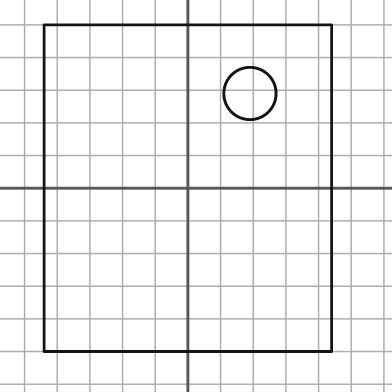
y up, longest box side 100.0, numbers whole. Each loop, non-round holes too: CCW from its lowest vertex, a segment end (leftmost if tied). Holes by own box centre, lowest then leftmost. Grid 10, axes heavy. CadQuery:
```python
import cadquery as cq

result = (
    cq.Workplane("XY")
    .moveTo(-44.0, -50.0)
    .lineTo(44.0, -50.0)
    .lineTo(44.0, 50.0)
    .lineTo(-44.0, 50.0)
    .close()
    .moveTo(19.0, 29.0)
    .circle(8.0)
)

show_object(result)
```